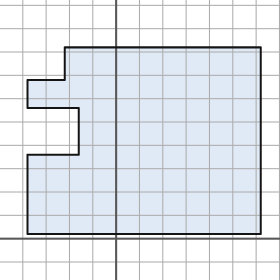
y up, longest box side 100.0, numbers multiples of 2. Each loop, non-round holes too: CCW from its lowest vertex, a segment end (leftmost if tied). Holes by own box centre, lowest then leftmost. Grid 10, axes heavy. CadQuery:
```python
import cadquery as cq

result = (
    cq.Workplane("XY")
    .moveTo(-38.0, 2.0)
    .lineTo(62.0, 2.0)
    .lineTo(62.0, 82.0)
    .lineTo(-22.0, 82.0)
    .lineTo(-22.0, 68.0)
    .lineTo(-38.0, 68.0)
    .lineTo(-38.0, 56.0)
    .lineTo(-16.0, 56.0)
    .lineTo(-16.0, 36.0)
    .lineTo(-38.0, 36.0)
    .close()
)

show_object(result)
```